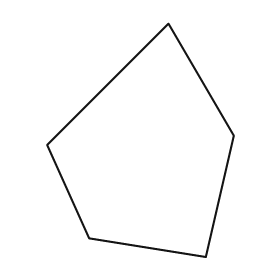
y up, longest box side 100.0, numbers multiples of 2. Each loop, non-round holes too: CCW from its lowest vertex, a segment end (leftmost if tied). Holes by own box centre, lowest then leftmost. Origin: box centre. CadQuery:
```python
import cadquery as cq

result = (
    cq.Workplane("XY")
    .moveTo(28.0, -50.0)
    .lineTo(40.0, 2.0)
    .lineTo(12.0, 50.0)
    .lineTo(-40.0, -2.0)
    .lineTo(-22.0, -42.0)
    .close()
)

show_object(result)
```